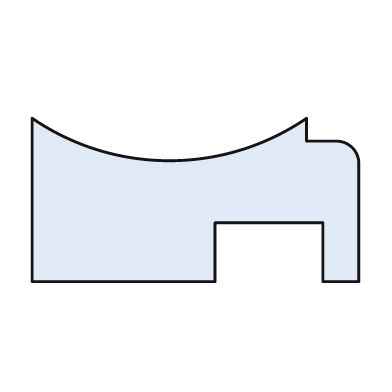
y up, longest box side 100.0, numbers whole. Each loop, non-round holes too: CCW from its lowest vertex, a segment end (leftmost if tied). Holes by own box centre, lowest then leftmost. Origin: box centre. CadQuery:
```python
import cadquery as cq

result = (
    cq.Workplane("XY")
    .moveTo(-50.0, -25.0)
    .lineTo(6.0, -25.0)
    .lineTo(6.0, -7.0)
    .lineTo(39.0, -7.0)
    .lineTo(39.0, -25.0)
    .lineTo(50.0, -25.0)
    .lineTo(50.0, 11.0)
    .threePointArc((48.0, 16.0), (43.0, 18.0))
    .lineTo(34.0, 18.0)
    .lineTo(34.0, 25.0)
    .threePointArc((-8.0, 12.0), (-50.0, 25.0))
    .close()
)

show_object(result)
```